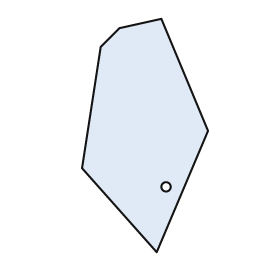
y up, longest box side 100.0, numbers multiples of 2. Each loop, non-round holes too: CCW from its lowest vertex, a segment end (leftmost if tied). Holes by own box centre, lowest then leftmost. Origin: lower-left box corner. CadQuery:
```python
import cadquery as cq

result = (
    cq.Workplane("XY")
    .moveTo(32.0, 0.0)
    .lineTo(54.0, 52.0)
    .lineTo(34.0, 100.0)
    .lineTo(16.0, 96.0)
    .lineTo(8.0, 88.0)
    .lineTo(0.0, 36.0)
    .close()
    .moveTo(36.0, 28.0)
    .circle(2.0)
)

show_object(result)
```